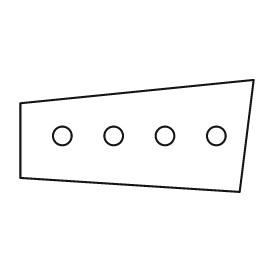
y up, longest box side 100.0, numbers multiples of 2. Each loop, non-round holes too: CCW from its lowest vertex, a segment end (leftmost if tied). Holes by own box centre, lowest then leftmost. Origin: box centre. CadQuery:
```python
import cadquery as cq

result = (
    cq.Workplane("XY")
    .moveTo(44.0, -24.0)
    .lineTo(50.0, 24.0)
    .lineTo(-50.0, 14.0)
    .lineTo(-50.0, -18.0)
    .close()
    .moveTo(-32.0, 0.0)
    .circle(4.0)
    .moveTo(-10.0, 0.0)
    .circle(4.0)
    .moveTo(12.0, 0.0)
    .circle(4.0)
    .moveTo(34.0, 0.0)
    .circle(4.0)
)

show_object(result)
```